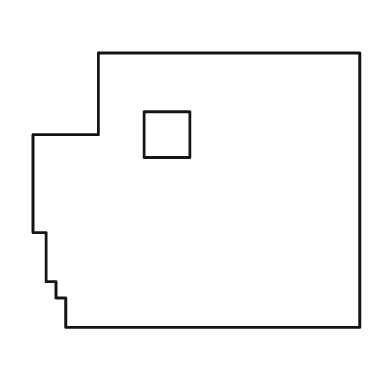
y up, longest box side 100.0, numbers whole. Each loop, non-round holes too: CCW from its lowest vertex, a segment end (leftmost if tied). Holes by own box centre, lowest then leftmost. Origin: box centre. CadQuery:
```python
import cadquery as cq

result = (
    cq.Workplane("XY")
    .moveTo(-40.0, -42.0)
    .lineTo(50.0, -42.0)
    .lineTo(50.0, 42.0)
    .lineTo(-30.0, 42.0)
    .lineTo(-30.0, 17.0)
    .lineTo(-50.0, 17.0)
    .lineTo(-50.0, -13.0)
    .lineTo(-46.0, -13.0)
    .lineTo(-46.0, -28.0)
    .lineTo(-43.0, -28.0)
    .lineTo(-43.0, -33.0)
    .lineTo(-40.0, -33.0)
    .close()
    .moveTo(-16.0, 10.0)
    .lineTo(-2.0, 10.0)
    .lineTo(-2.0, 24.0)
    .lineTo(-16.0, 24.0)
    .close()
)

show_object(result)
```